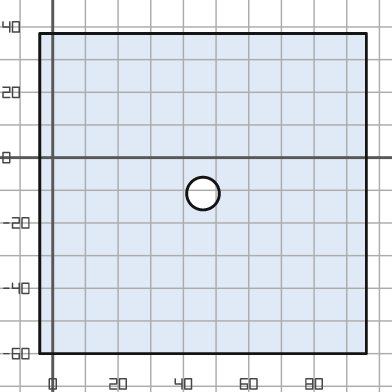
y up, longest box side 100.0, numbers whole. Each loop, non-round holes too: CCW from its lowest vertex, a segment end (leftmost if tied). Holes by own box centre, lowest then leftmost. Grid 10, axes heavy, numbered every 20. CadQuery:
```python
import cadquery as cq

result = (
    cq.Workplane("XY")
    .moveTo(-4.0, -60.0)
    .lineTo(96.0, -60.0)
    .lineTo(96.0, 38.0)
    .lineTo(-4.0, 38.0)
    .close()
    .moveTo(46.0, -11.0)
    .circle(5.0)
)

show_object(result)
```